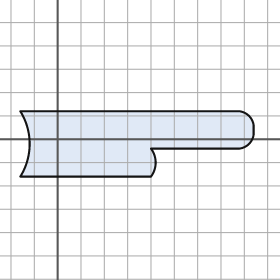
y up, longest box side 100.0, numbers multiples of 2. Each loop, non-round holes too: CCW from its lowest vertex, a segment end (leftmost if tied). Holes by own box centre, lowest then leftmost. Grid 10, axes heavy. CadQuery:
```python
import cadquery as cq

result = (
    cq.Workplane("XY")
    .moveTo(-16.0, -16.0)
    .lineTo(40.0, -16.0)
    .threePointArc((42.0, -10.0), (40.0, -4.0))
    .lineTo(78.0, -4.0)
    .threePointArc((82.0, -2.0), (84.0, 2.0))
    .lineTo(84.0, 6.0)
    .threePointArc((82.0, 10.0), (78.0, 12.0))
    .lineTo(-16.0, 12.0)
    .threePointArc((-12.0, -2.0), (-16.0, -16.0))
    .close()
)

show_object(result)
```